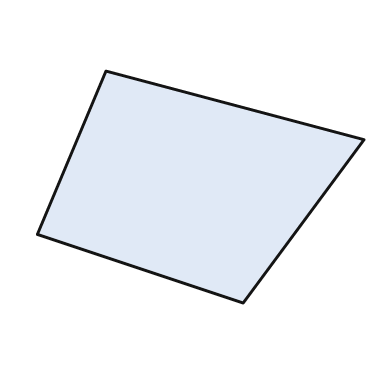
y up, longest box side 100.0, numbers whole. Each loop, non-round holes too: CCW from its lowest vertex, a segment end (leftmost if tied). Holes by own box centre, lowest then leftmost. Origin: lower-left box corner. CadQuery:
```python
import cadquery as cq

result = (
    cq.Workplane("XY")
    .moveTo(63.0, 0.0)
    .lineTo(100.0, 50.0)
    .lineTo(21.0, 71.0)
    .lineTo(0.0, 21.0)
    .close()
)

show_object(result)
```